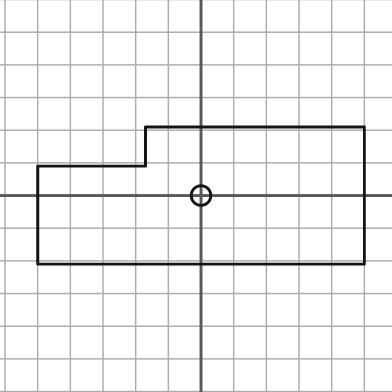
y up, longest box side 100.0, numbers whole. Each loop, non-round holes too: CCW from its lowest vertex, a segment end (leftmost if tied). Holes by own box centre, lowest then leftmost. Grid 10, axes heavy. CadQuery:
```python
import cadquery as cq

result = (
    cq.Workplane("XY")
    .moveTo(-50.0, -21.0)
    .lineTo(50.0, -21.0)
    .lineTo(50.0, 21.0)
    .lineTo(-17.0, 21.0)
    .lineTo(-17.0, 9.0)
    .lineTo(-50.0, 9.0)
    .close()
    .moveTo(0.0, 0.0)
    .circle(3.0)
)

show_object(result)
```